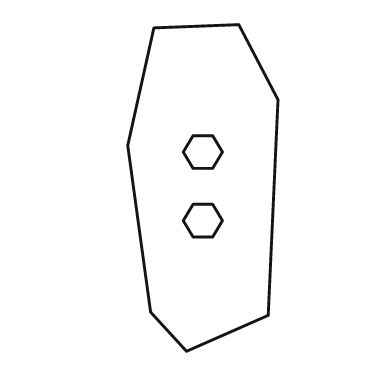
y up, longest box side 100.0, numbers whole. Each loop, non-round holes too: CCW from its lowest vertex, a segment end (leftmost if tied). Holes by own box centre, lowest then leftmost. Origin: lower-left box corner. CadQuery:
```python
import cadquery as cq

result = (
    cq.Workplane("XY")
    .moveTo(18.0, 0.0)
    .lineTo(43.0, 11.0)
    .lineTo(46.0, 77.0)
    .lineTo(34.0, 100.0)
    .lineTo(8.0, 99.0)
    .lineTo(0.0, 63.0)
    .lineTo(7.0, 12.0)
    .close()
    .moveTo(20.0, 35.0)
    .lineTo(26.0, 35.0)
    .lineTo(29.0, 40.0)
    .lineTo(26.0, 45.0)
    .lineTo(20.0, 45.0)
    .lineTo(17.0, 40.0)
    .close()
    .moveTo(20.0, 56.0)
    .lineTo(26.0, 56.0)
    .lineTo(29.0, 61.0)
    .lineTo(26.0, 66.0)
    .lineTo(20.0, 66.0)
    .lineTo(17.0, 61.0)
    .close()
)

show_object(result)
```